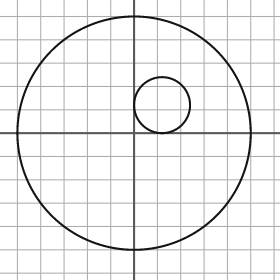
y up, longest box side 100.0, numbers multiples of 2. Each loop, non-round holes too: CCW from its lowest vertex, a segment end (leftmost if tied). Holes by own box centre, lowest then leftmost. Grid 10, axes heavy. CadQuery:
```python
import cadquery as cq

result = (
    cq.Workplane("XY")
    .moveTo(0.0, 0.0)
    .circle(50.0)
    .moveTo(12.0, 12.0)
    .circle(12.0)
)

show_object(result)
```